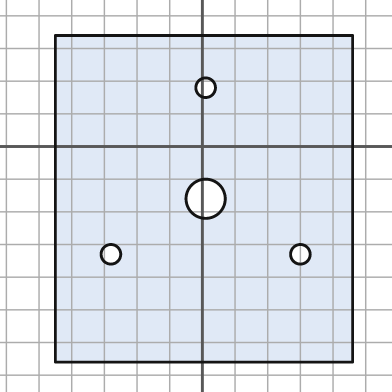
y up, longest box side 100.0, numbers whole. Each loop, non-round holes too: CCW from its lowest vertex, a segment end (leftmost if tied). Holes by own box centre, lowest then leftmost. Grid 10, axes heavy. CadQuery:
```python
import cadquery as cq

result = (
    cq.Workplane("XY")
    .moveTo(-45.0, -66.0)
    .lineTo(46.0, -66.0)
    .lineTo(46.0, 34.0)
    .lineTo(-45.0, 34.0)
    .close()
    .moveTo(-28.0, -33.0)
    .circle(3.0)
    .moveTo(30.0, -33.0)
    .circle(3.0)
    .moveTo(1.0, -16.0)
    .circle(6.0)
    .moveTo(1.0, 18.0)
    .circle(3.0)
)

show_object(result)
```